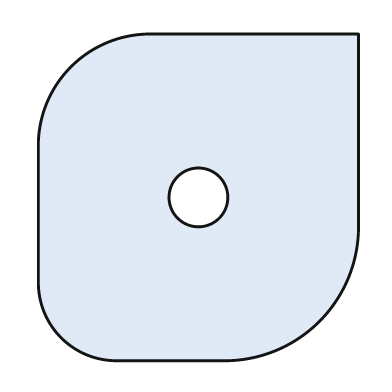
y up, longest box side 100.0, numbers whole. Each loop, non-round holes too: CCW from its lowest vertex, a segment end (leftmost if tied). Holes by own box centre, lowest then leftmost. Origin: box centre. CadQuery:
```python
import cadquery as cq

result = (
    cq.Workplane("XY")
    .moveTo(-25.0, -50.0)
    .lineTo(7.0, -50.0)
    .threePointArc((37.0, -38.0), (49.0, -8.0))
    .lineTo(49.0, 50.0)
    .lineTo(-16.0, 50.0)
    .threePointArc((-39.0, 40.0), (-49.0, 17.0))
    .lineTo(-49.0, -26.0)
    .threePointArc((-42.0, -43.0), (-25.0, -50.0))
    .close()
    .moveTo(0.0, 0.0)
    .circle(9.0)
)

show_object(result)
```